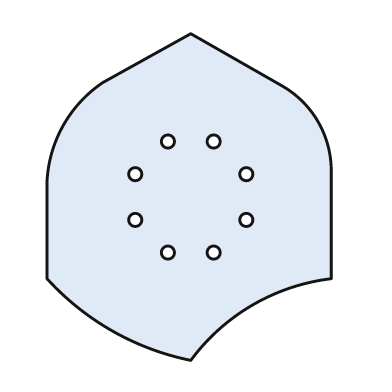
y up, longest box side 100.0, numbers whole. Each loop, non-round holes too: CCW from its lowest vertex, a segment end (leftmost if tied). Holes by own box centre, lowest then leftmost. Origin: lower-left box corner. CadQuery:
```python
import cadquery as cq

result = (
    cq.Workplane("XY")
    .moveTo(44.0, 0.0)
    .threePointArc((63.0, 17.0), (87.0, 25.0))
    .lineTo(87.0, 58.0)
    .threePointArc((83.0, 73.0), (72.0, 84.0))
    .lineTo(44.0, 100.0)
    .lineTo(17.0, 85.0)
    .threePointArc((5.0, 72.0), (0.0, 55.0))
    .lineTo(0.0, 25.0)
    .threePointArc((20.0, 9.0), (44.0, 0.0))
    .close()
    .moveTo(37.0, 33.0)
    .circle(2.0)
    .moveTo(51.0, 33.0)
    .circle(2.0)
    .moveTo(27.0, 43.0)
    .circle(2.0)
    .moveTo(61.0, 43.0)
    .circle(2.0)
    .moveTo(27.0, 57.0)
    .circle(2.0)
    .moveTo(61.0, 57.0)
    .circle(2.0)
    .moveTo(37.0, 67.0)
    .circle(2.0)
    .moveTo(51.0, 67.0)
    .circle(2.0)
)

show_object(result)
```